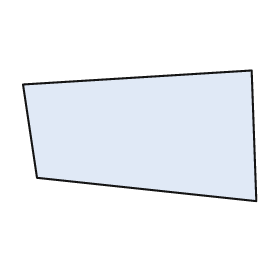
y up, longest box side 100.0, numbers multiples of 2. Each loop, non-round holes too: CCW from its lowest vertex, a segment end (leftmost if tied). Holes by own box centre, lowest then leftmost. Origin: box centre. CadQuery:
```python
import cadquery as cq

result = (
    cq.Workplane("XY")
    .moveTo(50.0, -28.0)
    .lineTo(48.0, 28.0)
    .lineTo(-50.0, 22.0)
    .lineTo(-44.0, -18.0)
    .close()
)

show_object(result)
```